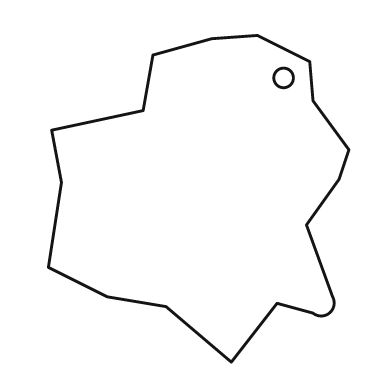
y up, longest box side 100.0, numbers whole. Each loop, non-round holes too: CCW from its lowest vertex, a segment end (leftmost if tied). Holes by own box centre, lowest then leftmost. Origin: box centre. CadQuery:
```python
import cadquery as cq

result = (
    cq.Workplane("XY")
    .moveTo(10.0, -50.0)
    .lineTo(24.0, -32.0)
    .lineTo(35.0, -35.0)
    .threePointArc((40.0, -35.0), (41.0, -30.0))
    .lineTo(33.0, -8.0)
    .lineTo(43.0, 6.0)
    .lineTo(46.0, 15.0)
    .lineTo(35.0, 30.0)
    .lineTo(34.0, 42.0)
    .lineTo(18.0, 50.0)
    .lineTo(4.0, 49.0)
    .lineTo(-14.0, 44.0)
    .lineTo(-17.0, 27.0)
    .lineTo(-45.0, 21.0)
    .lineTo(-42.0, 5.0)
    .lineTo(-46.0, -21.0)
    .lineTo(-28.0, -30.0)
    .lineTo(-10.0, -33.0)
    .close()
    .moveTo(26.0, 37.0)
    .circle(3.0)
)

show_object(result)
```